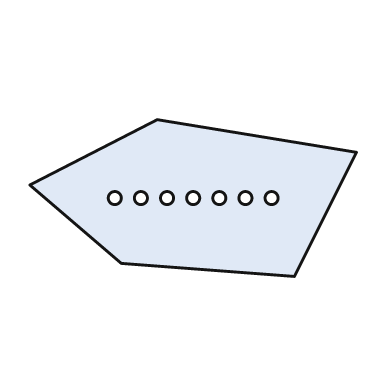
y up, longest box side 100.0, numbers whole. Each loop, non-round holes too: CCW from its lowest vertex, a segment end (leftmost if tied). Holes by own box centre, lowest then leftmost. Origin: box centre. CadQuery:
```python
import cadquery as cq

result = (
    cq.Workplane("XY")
    .moveTo(31.0, -24.0)
    .lineTo(50.0, 14.0)
    .lineTo(-11.0, 24.0)
    .lineTo(-50.0, 4.0)
    .lineTo(-22.0, -20.0)
    .close()
    .moveTo(-24.0, 0.0)
    .circle(2.0)
    .moveTo(-16.0, 0.0)
    .circle(2.0)
    .moveTo(-8.0, 0.0)
    .circle(2.0)
    .moveTo(0.0, 0.0)
    .circle(2.0)
    .moveTo(8.0, 0.0)
    .circle(2.0)
    .moveTo(16.0, 0.0)
    .circle(2.0)
    .moveTo(24.0, 0.0)
    .circle(2.0)
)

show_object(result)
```